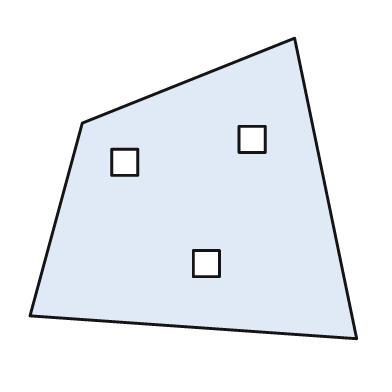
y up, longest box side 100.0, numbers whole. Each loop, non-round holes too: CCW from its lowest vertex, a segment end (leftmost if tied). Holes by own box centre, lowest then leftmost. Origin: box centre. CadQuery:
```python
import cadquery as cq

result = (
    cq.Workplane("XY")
    .moveTo(50.0, -46.0)
    .lineTo(31.0, 46.0)
    .lineTo(-34.0, 20.0)
    .lineTo(-50.0, -39.0)
    .close()
    .moveTo(0.0, -27.0)
    .lineTo(8.0, -27.0)
    .lineTo(8.0, -19.0)
    .lineTo(0.0, -19.0)
    .close()
    .moveTo(-25.0, 4.0)
    .lineTo(-17.0, 4.0)
    .lineTo(-17.0, 12.0)
    .lineTo(-25.0, 12.0)
    .close()
    .moveTo(14.0, 11.0)
    .lineTo(22.0, 11.0)
    .lineTo(22.0, 19.0)
    .lineTo(14.0, 19.0)
    .close()
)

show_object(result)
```